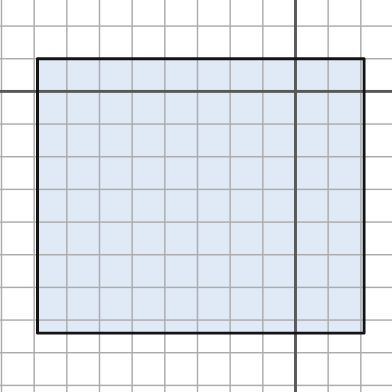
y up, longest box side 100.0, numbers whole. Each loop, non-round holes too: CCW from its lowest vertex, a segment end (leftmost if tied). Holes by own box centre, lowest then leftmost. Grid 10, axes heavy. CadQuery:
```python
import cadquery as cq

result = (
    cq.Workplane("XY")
    .moveTo(-79.0, -74.0)
    .lineTo(21.0, -74.0)
    .lineTo(21.0, 10.0)
    .lineTo(-79.0, 10.0)
    .close()
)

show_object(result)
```